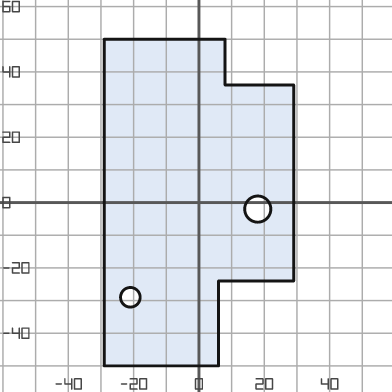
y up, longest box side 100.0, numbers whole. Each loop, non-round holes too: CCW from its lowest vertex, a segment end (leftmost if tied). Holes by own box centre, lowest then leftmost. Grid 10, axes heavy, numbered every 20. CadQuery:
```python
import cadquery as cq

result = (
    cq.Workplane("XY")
    .moveTo(-29.0, -50.0)
    .lineTo(6.0, -50.0)
    .lineTo(6.0, -24.0)
    .lineTo(29.0, -24.0)
    .lineTo(29.0, 36.0)
    .lineTo(8.0, 36.0)
    .lineTo(8.0, 50.0)
    .lineTo(-29.0, 50.0)
    .close()
    .moveTo(-21.0, -29.0)
    .circle(3.0)
    .moveTo(18.0, -2.0)
    .circle(4.0)
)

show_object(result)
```